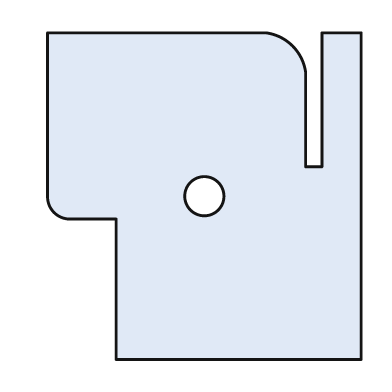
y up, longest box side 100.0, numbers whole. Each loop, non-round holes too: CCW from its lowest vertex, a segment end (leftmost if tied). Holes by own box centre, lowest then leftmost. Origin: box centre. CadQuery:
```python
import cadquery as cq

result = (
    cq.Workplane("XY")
    .moveTo(-27.0, -50.0)
    .lineTo(48.0, -50.0)
    .lineTo(48.0, 50.0)
    .lineTo(36.0, 50.0)
    .lineTo(36.0, 9.0)
    .lineTo(31.0, 9.0)
    .lineTo(31.0, 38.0)
    .threePointArc((27.0, 46.0), (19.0, 50.0))
    .lineTo(-48.0, 50.0)
    .lineTo(-48.0, 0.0)
    .threePointArc((-46.0, -5.0), (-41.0, -7.0))
    .lineTo(-27.0, -7.0)
    .close()
    .moveTo(0.0, 0.0)
    .circle(6.0)
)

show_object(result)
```